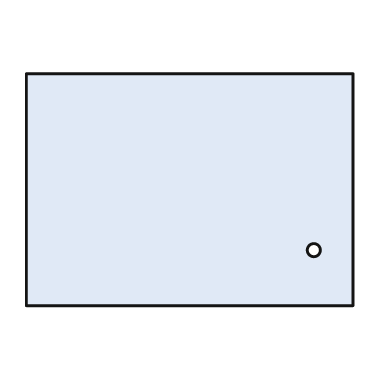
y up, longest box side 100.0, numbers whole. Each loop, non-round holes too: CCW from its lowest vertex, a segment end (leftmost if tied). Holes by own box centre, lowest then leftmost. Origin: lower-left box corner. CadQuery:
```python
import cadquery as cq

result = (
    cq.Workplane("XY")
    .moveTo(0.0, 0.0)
    .lineTo(100.0, 0.0)
    .lineTo(100.0, 71.0)
    .lineTo(0.0, 71.0)
    .close()
    .moveTo(88.0, 17.0)
    .circle(2.0)
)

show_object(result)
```